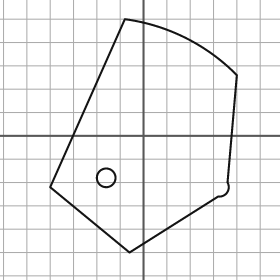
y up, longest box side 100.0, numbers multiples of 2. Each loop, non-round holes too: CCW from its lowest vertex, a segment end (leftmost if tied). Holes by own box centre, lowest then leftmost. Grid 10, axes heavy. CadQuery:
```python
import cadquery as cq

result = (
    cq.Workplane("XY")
    .moveTo(-6.0, -50.0)
    .lineTo(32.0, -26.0)
    .threePointArc((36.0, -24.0), (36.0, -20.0))
    .lineTo(40.0, 26.0)
    .threePointArc((18.0, 42.0), (-8.0, 50.0))
    .lineTo(-40.0, -22.0)
    .close()
    .moveTo(-16.0, -18.0)
    .circle(4.0)
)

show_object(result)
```